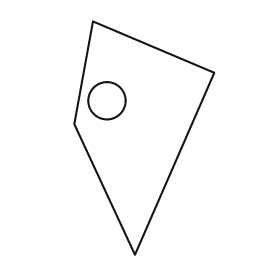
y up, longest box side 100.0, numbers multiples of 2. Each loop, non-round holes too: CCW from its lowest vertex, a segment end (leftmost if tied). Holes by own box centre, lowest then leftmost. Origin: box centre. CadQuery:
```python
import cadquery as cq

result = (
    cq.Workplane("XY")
    .moveTo(-4.0, -50.0)
    .lineTo(30.0, 28.0)
    .lineTo(-22.0, 50.0)
    .lineTo(-30.0, 6.0)
    .close()
    .moveTo(-16.0, 16.0)
    .circle(8.0)
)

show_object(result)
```